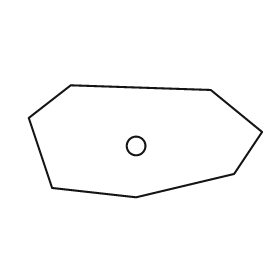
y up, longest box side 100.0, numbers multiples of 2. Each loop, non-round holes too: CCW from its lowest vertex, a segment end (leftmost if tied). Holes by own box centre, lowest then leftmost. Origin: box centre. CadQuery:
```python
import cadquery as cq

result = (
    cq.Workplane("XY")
    .moveTo(-4.0, -24.0)
    .lineTo(38.0, -14.0)
    .lineTo(50.0, 4.0)
    .lineTo(28.0, 22.0)
    .lineTo(-32.0, 24.0)
    .lineTo(-50.0, 10.0)
    .lineTo(-40.0, -20.0)
    .close()
    .moveTo(-4.0, -2.0)
    .circle(4.0)
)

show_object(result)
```